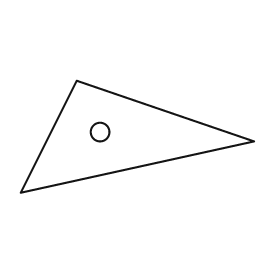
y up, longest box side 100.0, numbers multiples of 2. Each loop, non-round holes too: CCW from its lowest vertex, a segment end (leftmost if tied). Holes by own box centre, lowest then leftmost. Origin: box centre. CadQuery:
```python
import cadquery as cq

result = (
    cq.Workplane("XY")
    .moveTo(-50.0, -24.0)
    .lineTo(50.0, -2.0)
    .lineTo(-26.0, 24.0)
    .close()
    .moveTo(-16.0, 2.0)
    .circle(4.0)
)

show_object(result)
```